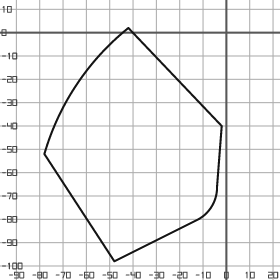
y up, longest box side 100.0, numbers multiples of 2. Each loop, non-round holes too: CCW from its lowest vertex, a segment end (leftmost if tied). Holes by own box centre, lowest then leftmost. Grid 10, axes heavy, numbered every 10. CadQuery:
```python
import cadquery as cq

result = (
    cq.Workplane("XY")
    .moveTo(-48.0, -98.0)
    .lineTo(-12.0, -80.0)
    .threePointArc((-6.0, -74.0), (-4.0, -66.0))
    .lineTo(-2.0, -40.0)
    .lineTo(-42.0, 2.0)
    .threePointArc((-64.0, -22.0), (-78.0, -52.0))
    .close()
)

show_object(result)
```